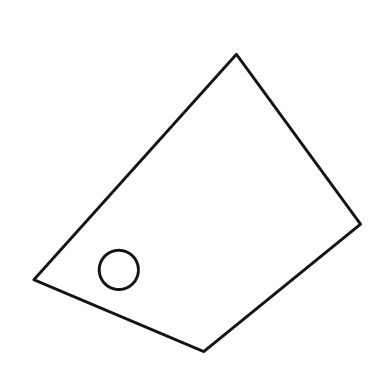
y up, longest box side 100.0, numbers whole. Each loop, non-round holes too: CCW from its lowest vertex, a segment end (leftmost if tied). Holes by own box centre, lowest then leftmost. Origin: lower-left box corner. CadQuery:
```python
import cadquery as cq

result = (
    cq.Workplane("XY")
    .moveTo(52.0, 0.0)
    .lineTo(100.0, 39.0)
    .lineTo(62.0, 91.0)
    .lineTo(0.0, 22.0)
    .close()
    .moveTo(26.0, 25.0)
    .circle(6.0)
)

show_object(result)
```